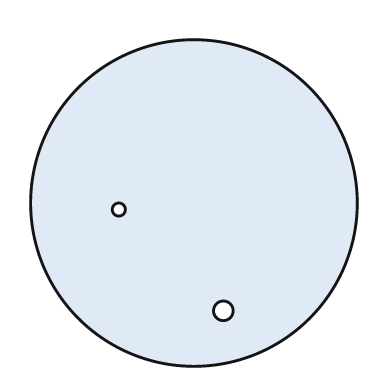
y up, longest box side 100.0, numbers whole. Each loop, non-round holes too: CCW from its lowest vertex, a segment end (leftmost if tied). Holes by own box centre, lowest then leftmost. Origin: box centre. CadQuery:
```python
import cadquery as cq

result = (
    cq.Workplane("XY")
    .moveTo(0.0, 0.0)
    .circle(50.0)
    .moveTo(9.0, -33.0)
    .circle(3.0)
    .moveTo(-23.0, -2.0)
    .circle(2.0)
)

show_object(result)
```